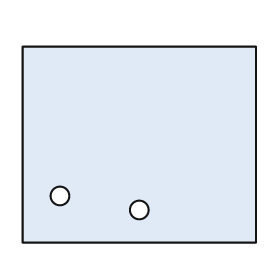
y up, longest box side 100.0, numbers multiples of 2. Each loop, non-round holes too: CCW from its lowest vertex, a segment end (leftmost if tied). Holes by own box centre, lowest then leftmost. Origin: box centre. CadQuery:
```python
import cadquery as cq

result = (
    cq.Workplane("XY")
    .moveTo(-50.0, -42.0)
    .lineTo(50.0, -42.0)
    .lineTo(50.0, 42.0)
    .lineTo(-50.0, 42.0)
    .close()
    .moveTo(0.0, -28.0)
    .circle(4.0)
    .moveTo(-34.0, -22.0)
    .circle(4.0)
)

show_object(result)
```